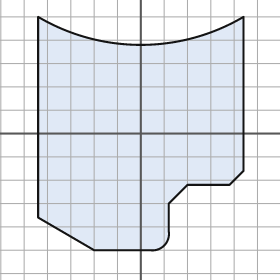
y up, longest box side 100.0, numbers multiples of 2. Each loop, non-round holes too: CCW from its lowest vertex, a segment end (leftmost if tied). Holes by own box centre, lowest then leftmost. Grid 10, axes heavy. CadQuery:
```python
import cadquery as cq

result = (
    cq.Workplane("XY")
    .moveTo(-20.0, -50.0)
    .lineTo(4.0, -50.0)
    .threePointArc((10.0, -48.0), (12.0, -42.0))
    .lineTo(12.0, -30.0)
    .lineTo(20.0, -22.0)
    .lineTo(38.0, -22.0)
    .lineTo(44.0, -16.0)
    .lineTo(44.0, 50.0)
    .threePointArc((0.0, 38.0), (-44.0, 50.0))
    .lineTo(-44.0, -36.0)
    .close()
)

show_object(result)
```